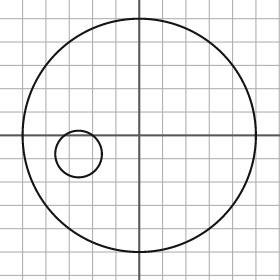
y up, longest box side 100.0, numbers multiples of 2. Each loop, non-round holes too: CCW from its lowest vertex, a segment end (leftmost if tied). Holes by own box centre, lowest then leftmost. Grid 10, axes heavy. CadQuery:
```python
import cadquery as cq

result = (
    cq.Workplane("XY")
    .moveTo(0.0, 0.0)
    .circle(50.0)
    .moveTo(-26.0, -8.0)
    .circle(10.0)
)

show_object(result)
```